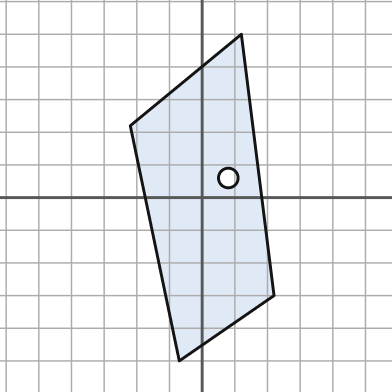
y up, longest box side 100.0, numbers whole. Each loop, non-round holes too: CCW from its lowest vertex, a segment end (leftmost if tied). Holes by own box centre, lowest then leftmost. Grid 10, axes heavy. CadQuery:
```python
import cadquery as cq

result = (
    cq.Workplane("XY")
    .moveTo(-7.0, -50.0)
    .lineTo(22.0, -30.0)
    .lineTo(12.0, 50.0)
    .lineTo(-22.0, 22.0)
    .close()
    .moveTo(8.0, 6.0)
    .circle(3.0)
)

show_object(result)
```